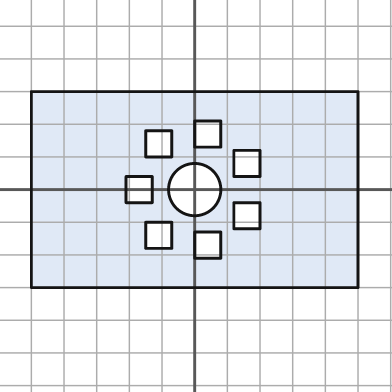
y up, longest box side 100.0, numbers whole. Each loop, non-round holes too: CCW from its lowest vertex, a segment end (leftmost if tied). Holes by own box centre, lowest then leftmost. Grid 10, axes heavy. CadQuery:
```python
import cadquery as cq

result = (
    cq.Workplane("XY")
    .moveTo(-50.0, -30.0)
    .lineTo(50.0, -30.0)
    .lineTo(50.0, 30.0)
    .lineTo(-50.0, 30.0)
    .close()
    .moveTo(0.0, -21.0)
    .lineTo(8.0, -21.0)
    .lineTo(8.0, -13.0)
    .lineTo(0.0, -13.0)
    .close()
    .moveTo(-15.0, -18.0)
    .lineTo(-7.0, -18.0)
    .lineTo(-7.0, -10.0)
    .lineTo(-15.0, -10.0)
    .close()
    .moveTo(12.0, -12.0)
    .lineTo(20.0, -12.0)
    .lineTo(20.0, -4.0)
    .lineTo(12.0, -4.0)
    .close()
    .moveTo(-21.0, -4.0)
    .lineTo(-13.0, -4.0)
    .lineTo(-13.0, 4.0)
    .lineTo(-21.0, 4.0)
    .close()
    .moveTo(0.0, 0.0)
    .circle(8.0)
    .moveTo(12.0, 4.0)
    .lineTo(20.0, 4.0)
    .lineTo(20.0, 12.0)
    .lineTo(12.0, 12.0)
    .close()
    .moveTo(-15.0, 10.0)
    .lineTo(-7.0, 10.0)
    .lineTo(-7.0, 18.0)
    .lineTo(-15.0, 18.0)
    .close()
    .moveTo(0.0, 13.0)
    .lineTo(8.0, 13.0)
    .lineTo(8.0, 21.0)
    .lineTo(0.0, 21.0)
    .close()
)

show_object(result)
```